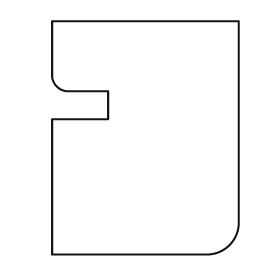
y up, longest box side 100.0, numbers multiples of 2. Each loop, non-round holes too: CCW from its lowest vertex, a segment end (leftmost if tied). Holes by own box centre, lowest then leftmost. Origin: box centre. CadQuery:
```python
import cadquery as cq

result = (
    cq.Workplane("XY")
    .moveTo(-40.0, -50.0)
    .lineTo(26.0, -50.0)
    .threePointArc((36.0, -46.0), (40.0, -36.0))
    .lineTo(40.0, 50.0)
    .lineTo(-40.0, 50.0)
    .lineTo(-40.0, 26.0)
    .threePointArc((-38.0, 22.0), (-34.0, 20.0))
    .lineTo(-16.0, 20.0)
    .lineTo(-16.0, 8.0)
    .lineTo(-40.0, 8.0)
    .close()
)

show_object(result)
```